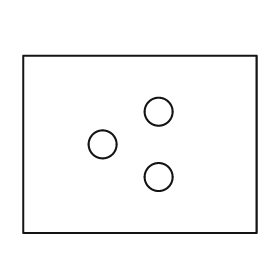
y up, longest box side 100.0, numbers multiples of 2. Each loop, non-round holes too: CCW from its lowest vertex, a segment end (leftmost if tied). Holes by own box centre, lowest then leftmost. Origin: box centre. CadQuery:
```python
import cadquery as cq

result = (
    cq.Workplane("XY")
    .moveTo(-50.0, -38.0)
    .lineTo(50.0, -38.0)
    .lineTo(50.0, 38.0)
    .lineTo(-50.0, 38.0)
    .close()
    .moveTo(8.0, -14.0)
    .circle(6.0)
    .moveTo(-16.0, 0.0)
    .circle(6.0)
    .moveTo(8.0, 14.0)
    .circle(6.0)
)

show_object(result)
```